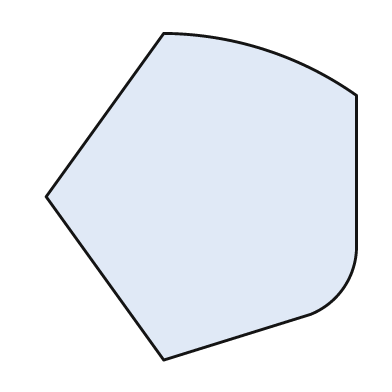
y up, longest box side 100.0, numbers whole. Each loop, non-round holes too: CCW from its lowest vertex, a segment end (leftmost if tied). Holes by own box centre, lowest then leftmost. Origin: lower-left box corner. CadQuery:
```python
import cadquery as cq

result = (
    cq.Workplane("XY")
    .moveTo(36.0, 0.0)
    .lineTo(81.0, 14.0)
    .threePointArc((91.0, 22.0), (95.0, 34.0))
    .lineTo(95.0, 81.0)
    .threePointArc((67.0, 95.0), (36.0, 100.0))
    .lineTo(0.0, 50.0)
    .close()
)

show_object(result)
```